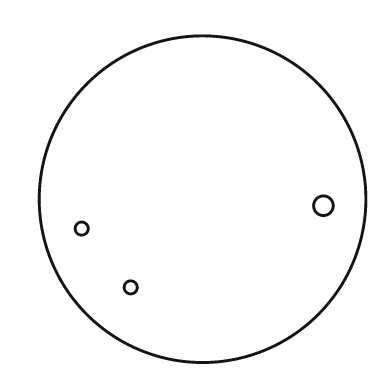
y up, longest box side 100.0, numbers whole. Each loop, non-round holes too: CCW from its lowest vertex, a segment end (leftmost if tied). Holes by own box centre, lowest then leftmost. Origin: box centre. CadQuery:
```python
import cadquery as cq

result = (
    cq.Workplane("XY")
    .moveTo(0.0, 0.0)
    .circle(50.0)
    .moveTo(-22.0, -27.0)
    .circle(2.0)
    .moveTo(-37.0, -9.0)
    .circle(2.0)
    .moveTo(37.0, -2.0)
    .circle(3.0)
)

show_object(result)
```